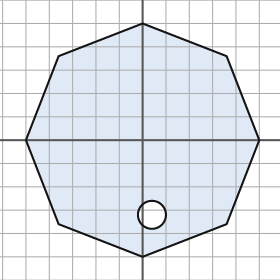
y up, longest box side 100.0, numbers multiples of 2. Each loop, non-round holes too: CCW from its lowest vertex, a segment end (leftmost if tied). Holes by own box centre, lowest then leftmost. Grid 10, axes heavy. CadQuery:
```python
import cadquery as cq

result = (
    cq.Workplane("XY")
    .moveTo(0.0, -50.0)
    .lineTo(36.0, -36.0)
    .lineTo(50.0, 0.0)
    .lineTo(36.0, 36.0)
    .lineTo(0.0, 50.0)
    .lineTo(-36.0, 36.0)
    .lineTo(-50.0, 0.0)
    .lineTo(-36.0, -36.0)
    .close()
    .moveTo(4.0, -32.0)
    .circle(6.0)
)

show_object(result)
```